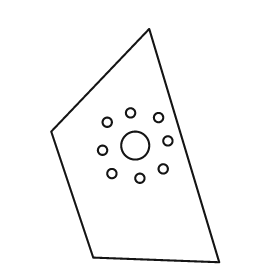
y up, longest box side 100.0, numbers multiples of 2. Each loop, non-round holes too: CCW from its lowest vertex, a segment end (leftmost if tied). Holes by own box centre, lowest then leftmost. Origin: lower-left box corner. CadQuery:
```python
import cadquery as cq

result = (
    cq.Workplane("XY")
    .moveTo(72.0, 0.0)
    .lineTo(42.0, 100.0)
    .lineTo(0.0, 56.0)
    .lineTo(18.0, 2.0)
    .close()
    .moveTo(38.0, 36.0)
    .circle(2.0)
    .moveTo(26.0, 38.0)
    .circle(2.0)
    .moveTo(48.0, 40.0)
    .circle(2.0)
    .moveTo(22.0, 48.0)
    .circle(2.0)
    .moveTo(36.0, 50.0)
    .circle(6.0)
    .moveTo(50.0, 52.0)
    .circle(2.0)
    .moveTo(24.0, 60.0)
    .circle(2.0)
    .moveTo(46.0, 62.0)
    .circle(2.0)
    .moveTo(34.0, 64.0)
    .circle(2.0)
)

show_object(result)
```